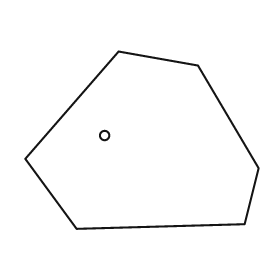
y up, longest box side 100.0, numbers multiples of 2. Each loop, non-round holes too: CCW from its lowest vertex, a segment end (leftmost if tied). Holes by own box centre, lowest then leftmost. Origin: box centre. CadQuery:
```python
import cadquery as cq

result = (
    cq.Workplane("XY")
    .moveTo(-28.0, -38.0)
    .lineTo(44.0, -36.0)
    .lineTo(50.0, -12.0)
    .lineTo(24.0, 32.0)
    .lineTo(-10.0, 38.0)
    .lineTo(-50.0, -8.0)
    .close()
    .moveTo(-16.0, 2.0)
    .circle(2.0)
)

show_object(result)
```